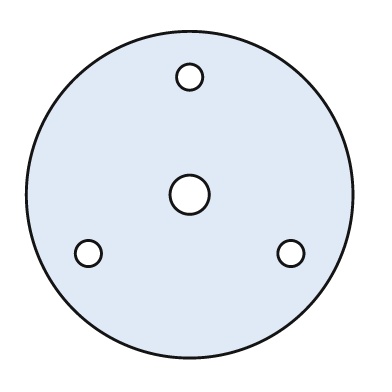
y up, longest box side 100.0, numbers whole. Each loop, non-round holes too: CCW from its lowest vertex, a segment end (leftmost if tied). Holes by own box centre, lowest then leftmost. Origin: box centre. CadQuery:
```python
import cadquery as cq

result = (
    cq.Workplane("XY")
    .moveTo(0.0, 0.0)
    .circle(50.0)
    .moveTo(-31.0, -18.0)
    .circle(4.0)
    .moveTo(31.0, -18.0)
    .circle(4.0)
    .moveTo(0.0, 0.0)
    .circle(6.0)
    .moveTo(0.0, 36.0)
    .circle(4.0)
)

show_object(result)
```